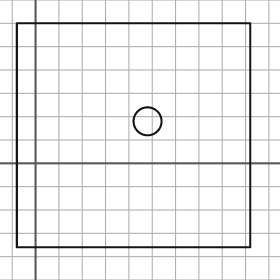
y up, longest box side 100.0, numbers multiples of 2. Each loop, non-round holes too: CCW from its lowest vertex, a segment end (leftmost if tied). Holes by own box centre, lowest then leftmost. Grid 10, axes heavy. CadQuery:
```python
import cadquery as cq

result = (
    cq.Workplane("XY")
    .moveTo(-8.0, -36.0)
    .lineTo(92.0, -36.0)
    .lineTo(92.0, 60.0)
    .lineTo(-8.0, 60.0)
    .close()
    .moveTo(48.0, 18.0)
    .circle(6.0)
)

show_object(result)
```